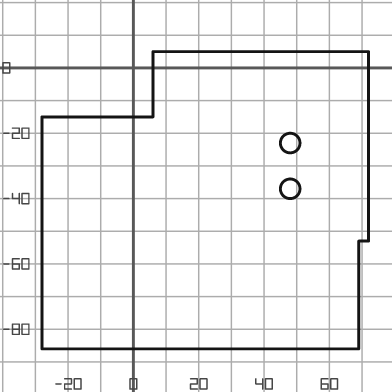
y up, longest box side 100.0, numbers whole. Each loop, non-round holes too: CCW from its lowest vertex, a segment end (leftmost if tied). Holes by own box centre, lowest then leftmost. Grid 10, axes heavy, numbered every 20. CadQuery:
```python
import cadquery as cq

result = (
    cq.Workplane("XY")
    .moveTo(-28.0, -86.0)
    .lineTo(69.0, -86.0)
    .lineTo(69.0, -53.0)
    .lineTo(72.0, -53.0)
    .lineTo(72.0, 5.0)
    .lineTo(6.0, 5.0)
    .lineTo(6.0, -15.0)
    .lineTo(-28.0, -15.0)
    .close()
    .moveTo(48.0, -37.0)
    .circle(3.0)
    .moveTo(48.0, -23.0)
    .circle(3.0)
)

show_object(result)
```